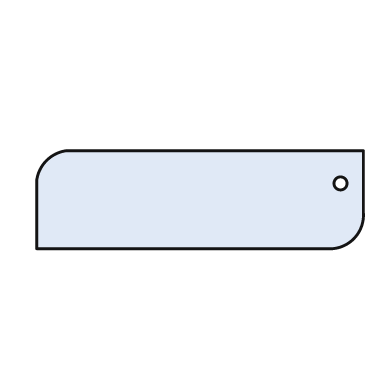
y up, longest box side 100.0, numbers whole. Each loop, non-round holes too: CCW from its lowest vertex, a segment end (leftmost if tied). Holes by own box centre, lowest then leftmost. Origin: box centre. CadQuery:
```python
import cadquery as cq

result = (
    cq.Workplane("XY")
    .moveTo(-50.0, -15.0)
    .lineTo(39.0, -15.0)
    .threePointArc((47.0, -12.0), (50.0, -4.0))
    .lineTo(50.0, 15.0)
    .lineTo(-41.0, 15.0)
    .threePointArc((-47.0, 12.0), (-50.0, 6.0))
    .close()
    .moveTo(43.0, 5.0)
    .circle(2.0)
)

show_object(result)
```